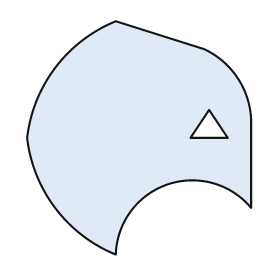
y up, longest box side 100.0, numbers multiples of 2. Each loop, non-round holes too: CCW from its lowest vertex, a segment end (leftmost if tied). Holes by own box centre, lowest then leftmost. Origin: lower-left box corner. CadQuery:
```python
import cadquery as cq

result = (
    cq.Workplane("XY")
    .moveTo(38.0, 0.0)
    .threePointArc((60.0, 30.0), (96.0, 20.0))
    .lineTo(96.0, 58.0)
    .threePointArc((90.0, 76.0), (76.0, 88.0))
    .lineTo(38.0, 100.0)
    .threePointArc((12.0, 80.0), (0.0, 50.0))
    .threePointArc((12.0, 20.0), (38.0, 0.0))
    .close()
    .moveTo(70.0, 50.0)
    .lineTo(86.0, 50.0)
    .lineTo(78.0, 62.0)
    .close()
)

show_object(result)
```